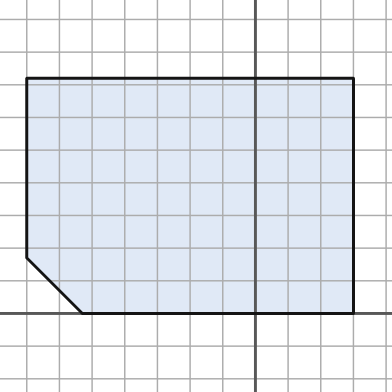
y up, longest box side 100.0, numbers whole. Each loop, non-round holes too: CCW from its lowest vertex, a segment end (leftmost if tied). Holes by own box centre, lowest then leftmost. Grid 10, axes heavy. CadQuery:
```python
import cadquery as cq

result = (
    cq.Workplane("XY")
    .moveTo(-53.0, 0.0)
    .lineTo(30.0, 0.0)
    .lineTo(30.0, 72.0)
    .lineTo(-70.0, 72.0)
    .lineTo(-70.0, 17.0)
    .close()
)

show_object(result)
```